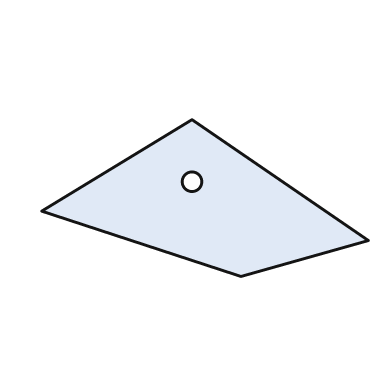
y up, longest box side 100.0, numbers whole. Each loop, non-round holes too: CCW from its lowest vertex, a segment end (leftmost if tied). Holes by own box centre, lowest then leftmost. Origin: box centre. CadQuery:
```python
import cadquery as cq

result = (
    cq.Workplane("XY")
    .moveTo(11.0, -24.0)
    .lineTo(50.0, -13.0)
    .lineTo(-4.0, 24.0)
    .lineTo(-50.0, -4.0)
    .close()
    .moveTo(-4.0, 5.0)
    .circle(3.0)
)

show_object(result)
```